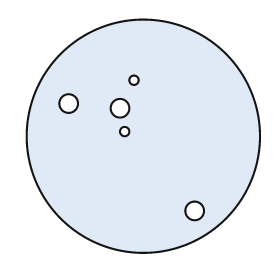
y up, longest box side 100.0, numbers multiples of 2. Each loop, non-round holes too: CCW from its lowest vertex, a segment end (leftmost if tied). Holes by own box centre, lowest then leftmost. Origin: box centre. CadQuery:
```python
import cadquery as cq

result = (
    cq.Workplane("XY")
    .moveTo(0.0, 0.0)
    .circle(50.0)
    .moveTo(22.0, -32.0)
    .circle(4.0)
    .moveTo(-8.0, 2.0)
    .circle(2.0)
    .moveTo(-10.0, 12.0)
    .circle(4.0)
    .moveTo(-32.0, 14.0)
    .circle(4.0)
    .moveTo(-4.0, 24.0)
    .circle(2.0)
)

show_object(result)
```